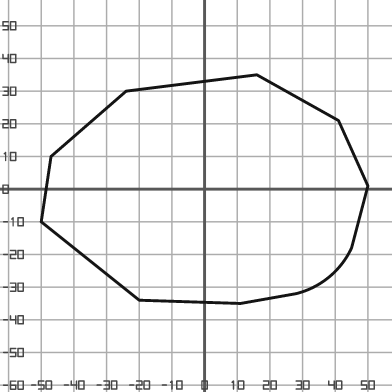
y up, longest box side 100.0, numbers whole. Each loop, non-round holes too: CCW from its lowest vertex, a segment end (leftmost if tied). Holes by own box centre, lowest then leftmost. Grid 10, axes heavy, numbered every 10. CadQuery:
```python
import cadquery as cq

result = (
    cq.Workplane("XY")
    .moveTo(11.0, -35.0)
    .lineTo(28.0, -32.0)
    .threePointArc((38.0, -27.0), (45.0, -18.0))
    .lineTo(50.0, 1.0)
    .lineTo(41.0, 21.0)
    .lineTo(16.0, 35.0)
    .lineTo(-24.0, 30.0)
    .lineTo(-47.0, 10.0)
    .lineTo(-50.0, -10.0)
    .lineTo(-20.0, -34.0)
    .close()
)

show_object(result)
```